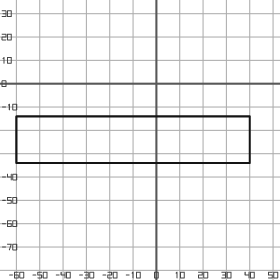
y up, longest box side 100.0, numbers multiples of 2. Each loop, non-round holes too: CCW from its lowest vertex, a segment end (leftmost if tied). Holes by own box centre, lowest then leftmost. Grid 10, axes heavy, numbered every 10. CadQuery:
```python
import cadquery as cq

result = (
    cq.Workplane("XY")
    .moveTo(-60.0, -34.0)
    .lineTo(40.0, -34.0)
    .lineTo(40.0, -14.0)
    .lineTo(-60.0, -14.0)
    .close()
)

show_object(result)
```